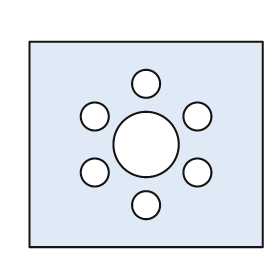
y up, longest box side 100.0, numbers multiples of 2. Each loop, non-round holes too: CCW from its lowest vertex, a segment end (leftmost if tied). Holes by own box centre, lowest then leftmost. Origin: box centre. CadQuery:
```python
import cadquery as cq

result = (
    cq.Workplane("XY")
    .moveTo(-50.0, -44.0)
    .lineTo(50.0, -44.0)
    .lineTo(50.0, 44.0)
    .lineTo(-50.0, 44.0)
    .close()
    .moveTo(0.0, -26.0)
    .circle(6.0)
    .moveTo(-22.0, -12.0)
    .circle(6.0)
    .moveTo(22.0, -12.0)
    .circle(6.0)
    .moveTo(0.0, 0.0)
    .circle(14.0)
    .moveTo(-22.0, 12.0)
    .circle(6.0)
    .moveTo(22.0, 12.0)
    .circle(6.0)
    .moveTo(0.0, 26.0)
    .circle(6.0)
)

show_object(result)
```